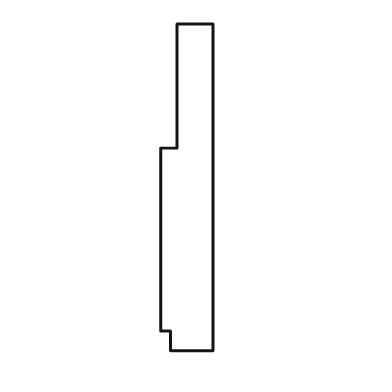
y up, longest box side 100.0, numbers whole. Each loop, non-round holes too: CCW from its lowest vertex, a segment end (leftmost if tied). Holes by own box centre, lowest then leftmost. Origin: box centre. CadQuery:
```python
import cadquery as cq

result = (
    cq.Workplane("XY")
    .moveTo(-5.0, -50.0)
    .lineTo(8.0, -50.0)
    .lineTo(8.0, 50.0)
    .lineTo(-3.0, 50.0)
    .lineTo(-3.0, 12.0)
    .lineTo(-8.0, 12.0)
    .lineTo(-8.0, -44.0)
    .lineTo(-5.0, -44.0)
    .close()
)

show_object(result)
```